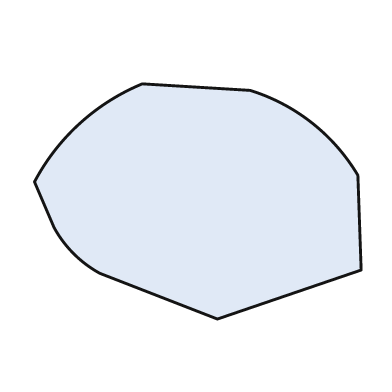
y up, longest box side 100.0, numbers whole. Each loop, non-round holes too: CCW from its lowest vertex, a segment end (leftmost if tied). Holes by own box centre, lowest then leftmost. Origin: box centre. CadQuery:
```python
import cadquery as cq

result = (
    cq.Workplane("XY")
    .moveTo(6.0, -36.0)
    .lineTo(50.0, -21.0)
    .lineTo(49.0, 8.0)
    .threePointArc((35.0, 24.0), (16.0, 34.0))
    .lineTo(-17.0, 36.0)
    .threePointArc((-36.0, 24.0), (-50.0, 6.0))
    .lineTo(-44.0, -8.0)
    .threePointArc((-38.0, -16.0), (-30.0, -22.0))
    .close()
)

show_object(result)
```